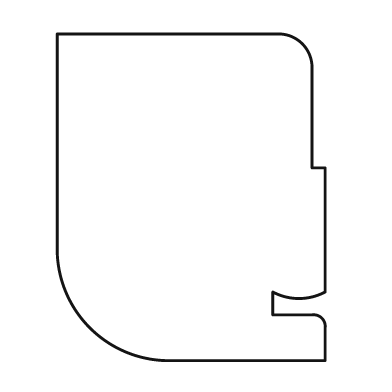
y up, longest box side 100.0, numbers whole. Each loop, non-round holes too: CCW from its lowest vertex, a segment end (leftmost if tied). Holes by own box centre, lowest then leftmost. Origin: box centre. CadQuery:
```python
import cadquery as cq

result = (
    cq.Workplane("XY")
    .moveTo(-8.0, -50.0)
    .lineTo(41.0, -50.0)
    .lineTo(41.0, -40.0)
    .threePointArc((40.0, -37.0), (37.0, -36.0))
    .lineTo(25.0, -36.0)
    .lineTo(25.0, -29.0)
    .threePointArc((33.0, -31.0), (41.0, -29.0))
    .lineTo(41.0, 9.0)
    .lineTo(37.0, 9.0)
    .lineTo(37.0, 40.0)
    .threePointArc((34.0, 47.0), (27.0, 50.0))
    .lineTo(-41.0, 50.0)
    .lineTo(-41.0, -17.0)
    .threePointArc((-31.0, -40.0), (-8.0, -50.0))
    .close()
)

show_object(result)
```